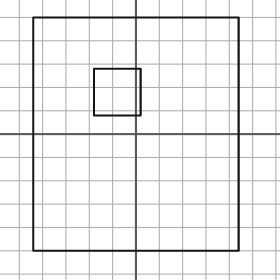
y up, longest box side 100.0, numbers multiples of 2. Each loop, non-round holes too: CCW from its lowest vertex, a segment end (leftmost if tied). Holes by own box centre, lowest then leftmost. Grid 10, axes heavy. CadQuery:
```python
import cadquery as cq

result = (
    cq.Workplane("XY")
    .moveTo(-44.0, -50.0)
    .lineTo(44.0, -50.0)
    .lineTo(44.0, 50.0)
    .lineTo(-44.0, 50.0)
    .close()
    .moveTo(-18.0, 8.0)
    .lineTo(2.0, 8.0)
    .lineTo(2.0, 28.0)
    .lineTo(-18.0, 28.0)
    .close()
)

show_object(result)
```